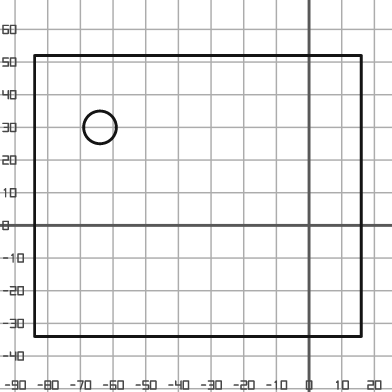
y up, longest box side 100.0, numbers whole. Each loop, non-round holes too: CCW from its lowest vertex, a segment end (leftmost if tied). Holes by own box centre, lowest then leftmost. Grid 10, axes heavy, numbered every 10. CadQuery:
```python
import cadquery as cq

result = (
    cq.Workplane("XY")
    .moveTo(-84.0, -34.0)
    .lineTo(16.0, -34.0)
    .lineTo(16.0, 52.0)
    .lineTo(-84.0, 52.0)
    .close()
    .moveTo(-64.0, 30.0)
    .circle(5.0)
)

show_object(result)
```